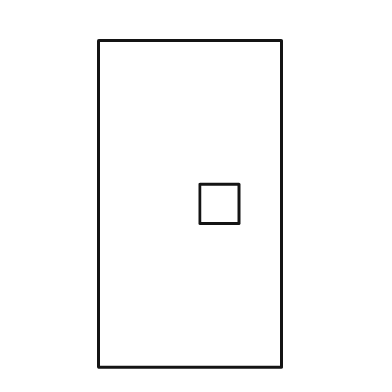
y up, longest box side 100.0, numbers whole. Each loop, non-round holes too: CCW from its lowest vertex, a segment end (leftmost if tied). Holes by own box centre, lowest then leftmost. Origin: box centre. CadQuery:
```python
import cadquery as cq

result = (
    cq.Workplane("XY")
    .moveTo(-28.0, -50.0)
    .lineTo(28.0, -50.0)
    .lineTo(28.0, 50.0)
    .lineTo(-28.0, 50.0)
    .close()
    .moveTo(3.0, -6.0)
    .lineTo(15.0, -6.0)
    .lineTo(15.0, 6.0)
    .lineTo(3.0, 6.0)
    .close()
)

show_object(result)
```